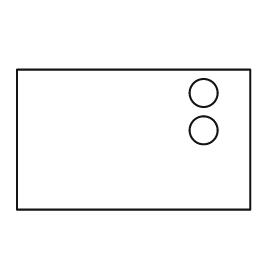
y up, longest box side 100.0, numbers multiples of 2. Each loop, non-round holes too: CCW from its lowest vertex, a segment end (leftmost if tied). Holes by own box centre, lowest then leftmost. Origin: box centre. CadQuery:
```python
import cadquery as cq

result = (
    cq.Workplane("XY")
    .moveTo(-50.0, -30.0)
    .lineTo(50.0, -30.0)
    .lineTo(50.0, 30.0)
    .lineTo(-50.0, 30.0)
    .close()
    .moveTo(30.0, 4.0)
    .circle(6.0)
    .moveTo(30.0, 20.0)
    .circle(6.0)
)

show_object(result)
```